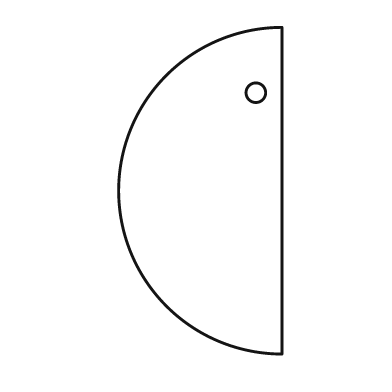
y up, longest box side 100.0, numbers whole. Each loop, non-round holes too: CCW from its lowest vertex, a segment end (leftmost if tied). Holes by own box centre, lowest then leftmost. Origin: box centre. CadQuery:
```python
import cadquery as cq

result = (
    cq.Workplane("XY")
    .moveTo(25.0, -50.0)
    .lineTo(25.0, 50.0)
    .threePointArc((-25.0, 0.0), (25.0, -50.0))
    .close()
    .moveTo(17.0, 30.0)
    .circle(3.0)
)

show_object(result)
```